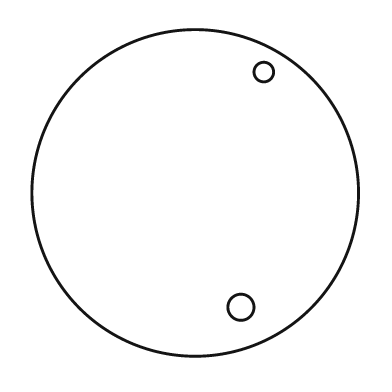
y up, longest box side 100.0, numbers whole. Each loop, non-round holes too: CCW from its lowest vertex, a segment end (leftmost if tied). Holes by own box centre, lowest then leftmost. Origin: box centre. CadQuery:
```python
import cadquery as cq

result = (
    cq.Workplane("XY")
    .moveTo(0.0, 0.0)
    .circle(50.0)
    .moveTo(14.0, -35.0)
    .circle(4.0)
    .moveTo(21.0, 37.0)
    .circle(3.0)
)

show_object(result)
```